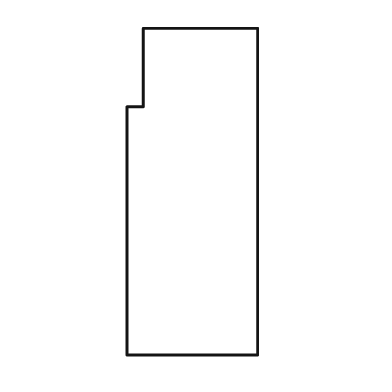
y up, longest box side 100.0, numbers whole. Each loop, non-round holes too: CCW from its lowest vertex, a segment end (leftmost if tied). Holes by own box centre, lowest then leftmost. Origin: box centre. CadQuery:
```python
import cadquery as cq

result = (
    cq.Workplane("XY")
    .moveTo(-20.0, -50.0)
    .lineTo(20.0, -50.0)
    .lineTo(20.0, 50.0)
    .lineTo(-15.0, 50.0)
    .lineTo(-15.0, 26.0)
    .lineTo(-20.0, 26.0)
    .close()
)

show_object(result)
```